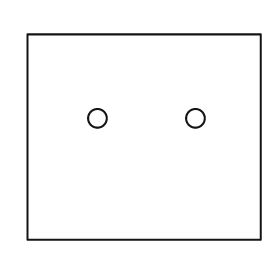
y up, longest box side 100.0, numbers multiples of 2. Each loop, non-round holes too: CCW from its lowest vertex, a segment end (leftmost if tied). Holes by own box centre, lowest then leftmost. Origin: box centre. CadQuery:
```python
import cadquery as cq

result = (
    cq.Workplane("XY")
    .moveTo(-50.0, -44.0)
    .lineTo(50.0, -44.0)
    .lineTo(50.0, 44.0)
    .lineTo(-50.0, 44.0)
    .close()
    .moveTo(-20.0, 8.0)
    .circle(4.0)
    .moveTo(22.0, 8.0)
    .circle(4.0)
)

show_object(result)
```